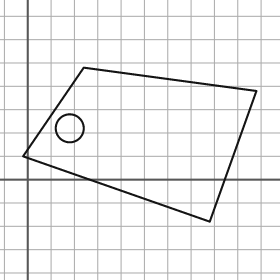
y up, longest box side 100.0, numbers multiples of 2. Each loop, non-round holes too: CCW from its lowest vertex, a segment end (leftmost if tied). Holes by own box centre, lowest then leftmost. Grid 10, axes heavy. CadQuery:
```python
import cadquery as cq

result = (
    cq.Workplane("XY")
    .moveTo(78.0, -18.0)
    .lineTo(98.0, 38.0)
    .lineTo(24.0, 48.0)
    .lineTo(-2.0, 10.0)
    .close()
    .moveTo(18.0, 22.0)
    .circle(6.0)
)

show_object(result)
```